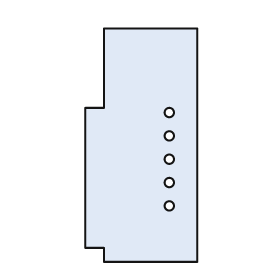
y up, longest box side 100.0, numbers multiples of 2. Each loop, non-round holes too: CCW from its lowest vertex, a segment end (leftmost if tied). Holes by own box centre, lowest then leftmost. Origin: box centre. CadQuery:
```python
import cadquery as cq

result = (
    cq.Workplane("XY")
    .moveTo(-16.0, -50.0)
    .lineTo(24.0, -50.0)
    .lineTo(24.0, 50.0)
    .lineTo(-16.0, 50.0)
    .lineTo(-16.0, 16.0)
    .lineTo(-24.0, 16.0)
    .lineTo(-24.0, -44.0)
    .lineTo(-16.0, -44.0)
    .close()
    .moveTo(12.0, -26.0)
    .circle(2.0)
    .moveTo(12.0, -16.0)
    .circle(2.0)
    .moveTo(12.0, -6.0)
    .circle(2.0)
    .moveTo(12.0, 4.0)
    .circle(2.0)
    .moveTo(12.0, 14.0)
    .circle(2.0)
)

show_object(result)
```